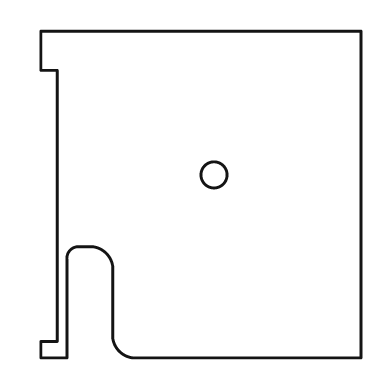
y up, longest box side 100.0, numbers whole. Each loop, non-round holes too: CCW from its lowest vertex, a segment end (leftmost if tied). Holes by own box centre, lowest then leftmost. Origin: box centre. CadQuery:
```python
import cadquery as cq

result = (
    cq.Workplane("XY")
    .moveTo(-49.0, -50.0)
    .lineTo(-41.0, -50.0)
    .lineTo(-41.0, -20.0)
    .threePointArc((-40.0, -17.0), (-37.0, -16.0))
    .lineTo(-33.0, -16.0)
    .threePointArc((-29.0, -18.0), (-27.0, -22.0))
    .lineTo(-27.0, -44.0)
    .threePointArc((-25.0, -48.0), (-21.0, -50.0))
    .lineTo(49.0, -50.0)
    .lineTo(49.0, 50.0)
    .lineTo(-49.0, 50.0)
    .lineTo(-49.0, 38.0)
    .lineTo(-44.0, 38.0)
    .lineTo(-44.0, -45.0)
    .lineTo(-49.0, -45.0)
    .close()
    .moveTo(4.0, 6.0)
    .circle(4.0)
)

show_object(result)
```